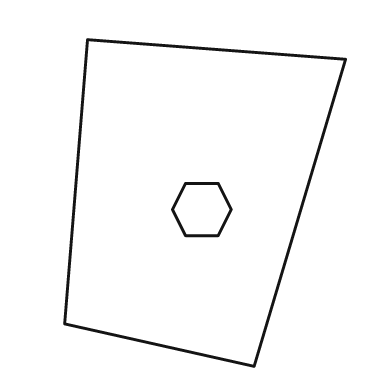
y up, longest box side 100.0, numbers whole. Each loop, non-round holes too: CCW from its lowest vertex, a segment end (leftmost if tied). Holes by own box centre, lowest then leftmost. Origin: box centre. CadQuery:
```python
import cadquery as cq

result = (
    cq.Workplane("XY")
    .moveTo(15.0, -50.0)
    .lineTo(43.0, 44.0)
    .lineTo(-36.0, 50.0)
    .lineTo(-43.0, -37.0)
    .close()
    .moveTo(-6.0, -10.0)
    .lineTo(4.0, -10.0)
    .lineTo(8.0, -2.0)
    .lineTo(4.0, 6.0)
    .lineTo(-6.0, 6.0)
    .lineTo(-10.0, -2.0)
    .close()
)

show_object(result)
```